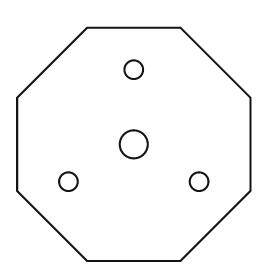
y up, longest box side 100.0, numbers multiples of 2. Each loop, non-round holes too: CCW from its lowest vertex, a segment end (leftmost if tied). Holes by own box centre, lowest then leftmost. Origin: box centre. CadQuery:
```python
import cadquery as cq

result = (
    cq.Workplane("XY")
    .moveTo(-20.0, -50.0)
    .lineTo(20.0, -50.0)
    .lineTo(50.0, -20.0)
    .lineTo(50.0, 20.0)
    .lineTo(20.0, 50.0)
    .lineTo(-20.0, 50.0)
    .lineTo(-50.0, 20.0)
    .lineTo(-50.0, -20.0)
    .close()
    .moveTo(-28.0, -16.0)
    .circle(4.0)
    .moveTo(28.0, -16.0)
    .circle(4.0)
    .moveTo(0.0, 0.0)
    .circle(6.0)
    .moveTo(0.0, 32.0)
    .circle(4.0)
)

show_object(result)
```